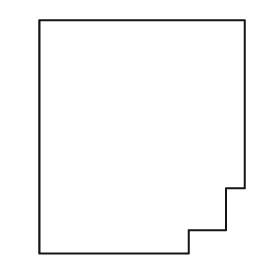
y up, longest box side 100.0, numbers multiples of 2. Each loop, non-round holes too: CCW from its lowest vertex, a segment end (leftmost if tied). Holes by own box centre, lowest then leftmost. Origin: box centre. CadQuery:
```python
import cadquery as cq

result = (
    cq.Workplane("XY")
    .moveTo(-44.0, -50.0)
    .lineTo(20.0, -50.0)
    .lineTo(20.0, -40.0)
    .lineTo(36.0, -40.0)
    .lineTo(36.0, -22.0)
    .lineTo(44.0, -22.0)
    .lineTo(44.0, 50.0)
    .lineTo(-44.0, 50.0)
    .close()
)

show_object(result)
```